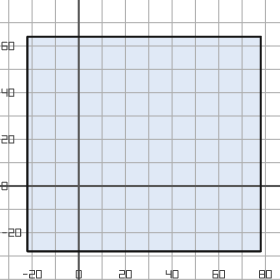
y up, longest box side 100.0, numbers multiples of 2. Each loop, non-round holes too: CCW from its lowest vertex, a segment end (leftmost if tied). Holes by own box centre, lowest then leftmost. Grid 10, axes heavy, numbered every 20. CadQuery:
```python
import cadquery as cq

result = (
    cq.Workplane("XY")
    .moveTo(-22.0, -28.0)
    .lineTo(78.0, -28.0)
    .lineTo(78.0, 64.0)
    .lineTo(-22.0, 64.0)
    .close()
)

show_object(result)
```